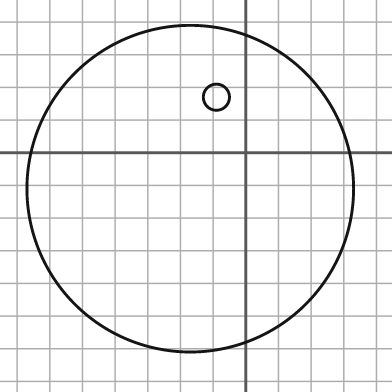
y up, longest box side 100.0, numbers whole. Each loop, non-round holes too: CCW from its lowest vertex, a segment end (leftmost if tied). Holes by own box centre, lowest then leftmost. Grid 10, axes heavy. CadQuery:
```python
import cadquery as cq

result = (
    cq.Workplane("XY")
    .moveTo(-17.0, -11.0)
    .circle(50.0)
    .moveTo(-9.0, 17.0)
    .circle(4.0)
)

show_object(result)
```